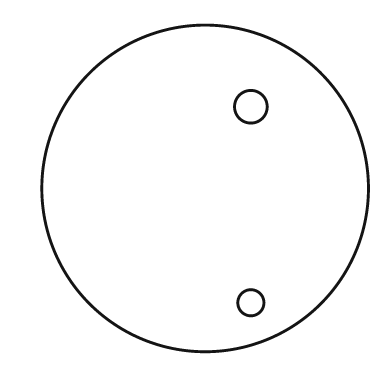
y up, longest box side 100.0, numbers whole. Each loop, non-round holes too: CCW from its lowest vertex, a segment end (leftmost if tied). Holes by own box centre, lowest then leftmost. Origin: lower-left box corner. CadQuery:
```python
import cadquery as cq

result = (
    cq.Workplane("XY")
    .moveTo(50.0, 50.0)
    .circle(50.0)
    .moveTo(64.0, 15.0)
    .circle(4.0)
    .moveTo(64.0, 75.0)
    .circle(5.0)
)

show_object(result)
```